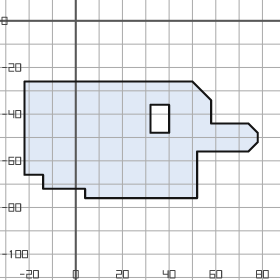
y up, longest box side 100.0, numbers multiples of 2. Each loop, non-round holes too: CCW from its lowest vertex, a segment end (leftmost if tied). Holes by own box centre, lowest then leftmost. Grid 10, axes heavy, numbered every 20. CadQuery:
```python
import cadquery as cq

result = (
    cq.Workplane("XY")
    .moveTo(4.0, -76.0)
    .lineTo(52.0, -76.0)
    .lineTo(52.0, -56.0)
    .lineTo(74.0, -56.0)
    .lineTo(78.0, -52.0)
    .lineTo(78.0, -48.0)
    .lineTo(74.0, -44.0)
    .lineTo(58.0, -44.0)
    .lineTo(58.0, -34.0)
    .lineTo(50.0, -26.0)
    .lineTo(-22.0, -26.0)
    .lineTo(-22.0, -66.0)
    .lineTo(-14.0, -66.0)
    .lineTo(-14.0, -72.0)
    .lineTo(4.0, -72.0)
    .close()
    .moveTo(32.0, -48.0)
    .lineTo(40.0, -48.0)
    .lineTo(40.0, -36.0)
    .lineTo(32.0, -36.0)
    .close()
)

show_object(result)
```